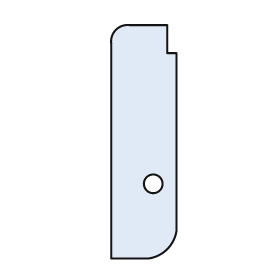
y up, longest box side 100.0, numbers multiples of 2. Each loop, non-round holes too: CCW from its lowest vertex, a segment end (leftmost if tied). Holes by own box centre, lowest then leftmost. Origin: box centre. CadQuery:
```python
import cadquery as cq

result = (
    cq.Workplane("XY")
    .moveTo(-14.0, -50.0)
    .lineTo(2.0, -50.0)
    .threePointArc((10.0, -46.0), (14.0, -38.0))
    .lineTo(14.0, 38.0)
    .lineTo(10.0, 38.0)
    .lineTo(10.0, 50.0)
    .lineTo(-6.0, 50.0)
    .threePointArc((-12.0, 48.0), (-14.0, 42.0))
    .close()
    .moveTo(4.0, -18.0)
    .circle(4.0)
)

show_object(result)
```